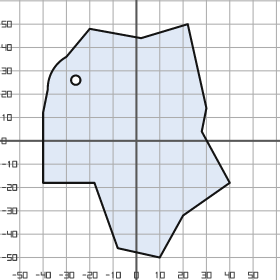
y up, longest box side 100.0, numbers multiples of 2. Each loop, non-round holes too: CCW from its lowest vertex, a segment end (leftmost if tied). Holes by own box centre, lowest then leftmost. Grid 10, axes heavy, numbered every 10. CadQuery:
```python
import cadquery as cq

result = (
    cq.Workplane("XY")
    .moveTo(10.0, -50.0)
    .lineTo(20.0, -32.0)
    .lineTo(40.0, -18.0)
    .lineTo(28.0, 4.0)
    .lineTo(30.0, 14.0)
    .lineTo(22.0, 50.0)
    .lineTo(2.0, 44.0)
    .lineTo(-20.0, 48.0)
    .lineTo(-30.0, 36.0)
    .threePointArc((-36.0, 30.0), (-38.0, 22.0))
    .lineTo(-40.0, 12.0)
    .lineTo(-40.0, -18.0)
    .lineTo(-18.0, -18.0)
    .lineTo(-8.0, -46.0)
    .close()
    .moveTo(-26.0, 26.0)
    .circle(2.0)
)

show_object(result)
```